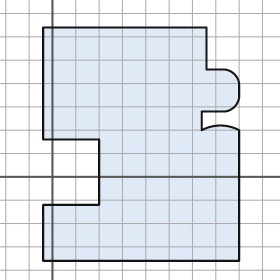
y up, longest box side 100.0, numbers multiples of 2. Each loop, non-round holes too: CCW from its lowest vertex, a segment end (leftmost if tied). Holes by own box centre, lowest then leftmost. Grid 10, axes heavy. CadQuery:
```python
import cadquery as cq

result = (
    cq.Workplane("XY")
    .moveTo(-4.0, -36.0)
    .lineTo(80.0, -36.0)
    .lineTo(80.0, 20.0)
    .threePointArc((72.0, 22.0), (64.0, 20.0))
    .lineTo(64.0, 28.0)
    .lineTo(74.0, 28.0)
    .threePointArc((78.0, 30.0), (80.0, 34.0))
    .lineTo(80.0, 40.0)
    .threePointArc((78.0, 44.0), (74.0, 46.0))
    .lineTo(66.0, 46.0)
    .lineTo(66.0, 64.0)
    .lineTo(-4.0, 64.0)
    .lineTo(-4.0, 16.0)
    .lineTo(20.0, 16.0)
    .lineTo(20.0, -12.0)
    .lineTo(-4.0, -12.0)
    .close()
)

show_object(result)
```